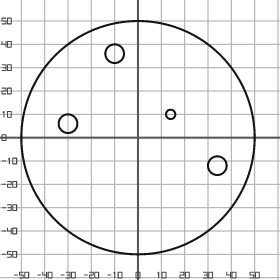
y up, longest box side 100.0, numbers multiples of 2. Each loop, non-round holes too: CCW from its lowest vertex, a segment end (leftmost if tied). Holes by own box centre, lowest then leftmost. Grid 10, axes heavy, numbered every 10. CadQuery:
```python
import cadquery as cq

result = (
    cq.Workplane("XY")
    .moveTo(0.0, 0.0)
    .circle(50.0)
    .moveTo(34.0, -12.0)
    .circle(4.0)
    .moveTo(-30.0, 6.0)
    .circle(4.0)
    .moveTo(14.0, 10.0)
    .circle(2.0)
    .moveTo(-10.0, 36.0)
    .circle(4.0)
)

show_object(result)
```